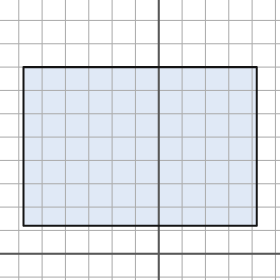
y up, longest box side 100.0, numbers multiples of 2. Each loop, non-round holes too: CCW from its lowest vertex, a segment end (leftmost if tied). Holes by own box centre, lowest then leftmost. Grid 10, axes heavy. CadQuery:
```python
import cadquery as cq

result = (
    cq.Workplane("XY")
    .moveTo(-58.0, 12.0)
    .lineTo(42.0, 12.0)
    .lineTo(42.0, 80.0)
    .lineTo(-58.0, 80.0)
    .close()
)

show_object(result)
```